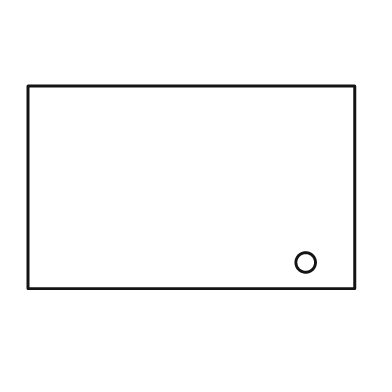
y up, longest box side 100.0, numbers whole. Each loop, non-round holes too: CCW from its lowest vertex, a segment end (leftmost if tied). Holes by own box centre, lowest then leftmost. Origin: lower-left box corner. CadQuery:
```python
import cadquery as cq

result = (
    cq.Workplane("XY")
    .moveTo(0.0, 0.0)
    .lineTo(100.0, 0.0)
    .lineTo(100.0, 62.0)
    .lineTo(0.0, 62.0)
    .close()
    .moveTo(85.0, 8.0)
    .circle(3.0)
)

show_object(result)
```